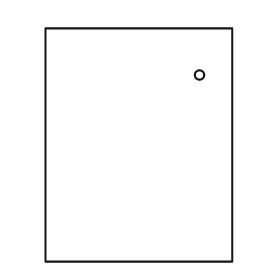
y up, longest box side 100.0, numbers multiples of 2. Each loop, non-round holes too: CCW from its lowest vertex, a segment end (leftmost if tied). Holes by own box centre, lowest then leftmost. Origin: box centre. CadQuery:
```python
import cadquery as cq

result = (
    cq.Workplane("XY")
    .moveTo(-40.0, -50.0)
    .lineTo(40.0, -50.0)
    .lineTo(40.0, 50.0)
    .lineTo(-40.0, 50.0)
    .close()
    .moveTo(26.0, 30.0)
    .circle(2.0)
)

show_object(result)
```